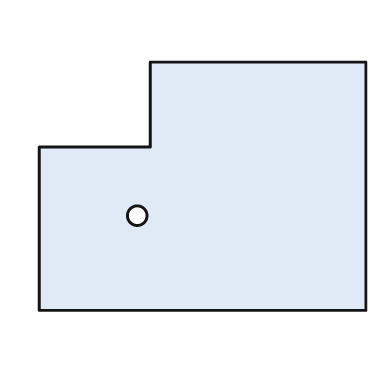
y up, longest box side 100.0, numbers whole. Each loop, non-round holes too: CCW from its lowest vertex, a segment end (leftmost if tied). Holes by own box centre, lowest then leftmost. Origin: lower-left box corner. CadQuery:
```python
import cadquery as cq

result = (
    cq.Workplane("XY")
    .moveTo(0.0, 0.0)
    .lineTo(100.0, 0.0)
    .lineTo(100.0, 76.0)
    .lineTo(34.0, 76.0)
    .lineTo(34.0, 50.0)
    .lineTo(0.0, 50.0)
    .close()
    .moveTo(30.0, 29.0)
    .circle(3.0)
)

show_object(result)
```